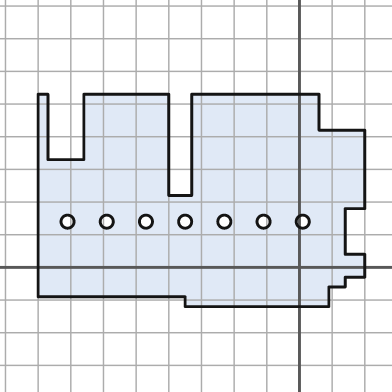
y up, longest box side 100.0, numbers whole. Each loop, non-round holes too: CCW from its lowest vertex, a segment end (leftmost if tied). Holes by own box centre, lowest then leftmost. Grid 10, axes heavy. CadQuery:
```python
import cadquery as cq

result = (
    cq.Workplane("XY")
    .moveTo(-35.0, -12.0)
    .lineTo(9.0, -12.0)
    .lineTo(9.0, -6.0)
    .lineTo(14.0, -6.0)
    .lineTo(14.0, -3.0)
    .lineTo(20.0, -3.0)
    .lineTo(20.0, 4.0)
    .lineTo(14.0, 4.0)
    .lineTo(14.0, 18.0)
    .lineTo(20.0, 18.0)
    .lineTo(20.0, 42.0)
    .lineTo(6.0, 42.0)
    .lineTo(6.0, 53.0)
    .lineTo(-33.0, 53.0)
    .lineTo(-33.0, 22.0)
    .lineTo(-40.0, 22.0)
    .lineTo(-40.0, 53.0)
    .lineTo(-66.0, 53.0)
    .lineTo(-66.0, 33.0)
    .lineTo(-77.0, 33.0)
    .lineTo(-77.0, 53.0)
    .lineTo(-80.0, 53.0)
    .lineTo(-80.0, -9.0)
    .lineTo(-35.0, -9.0)
    .close()
    .moveTo(-71.0, 14.0)
    .circle(2.0)
    .moveTo(-59.0, 14.0)
    .circle(2.0)
    .moveTo(-47.0, 14.0)
    .circle(2.0)
    .moveTo(-35.0, 14.0)
    .circle(2.0)
    .moveTo(-23.0, 14.0)
    .circle(2.0)
    .moveTo(-11.0, 14.0)
    .circle(2.0)
    .moveTo(1.0, 14.0)
    .circle(2.0)
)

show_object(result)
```